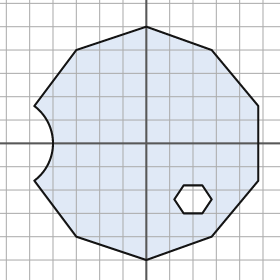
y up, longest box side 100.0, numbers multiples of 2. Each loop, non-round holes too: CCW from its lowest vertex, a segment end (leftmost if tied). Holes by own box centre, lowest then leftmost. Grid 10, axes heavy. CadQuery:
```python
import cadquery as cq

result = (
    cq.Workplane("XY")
    .moveTo(0.0, -50.0)
    .lineTo(28.0, -40.0)
    .lineTo(48.0, -16.0)
    .lineTo(48.0, 16.0)
    .lineTo(28.0, 40.0)
    .lineTo(0.0, 50.0)
    .lineTo(-30.0, 40.0)
    .lineTo(-48.0, 16.0)
    .threePointArc((-40.0, 0.0), (-48.0, -16.0))
    .lineTo(-30.0, -40.0)
    .close()
    .moveTo(16.0, -30.0)
    .lineTo(24.0, -30.0)
    .lineTo(28.0, -24.0)
    .lineTo(24.0, -18.0)
    .lineTo(16.0, -18.0)
    .lineTo(12.0, -24.0)
    .close()
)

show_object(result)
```